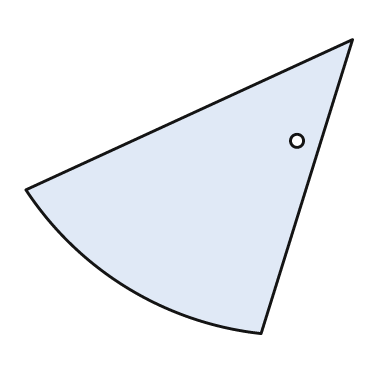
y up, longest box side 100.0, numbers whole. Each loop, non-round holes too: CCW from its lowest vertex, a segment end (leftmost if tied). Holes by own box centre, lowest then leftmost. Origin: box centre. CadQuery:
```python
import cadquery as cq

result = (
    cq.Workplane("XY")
    .moveTo(22.0, -45.0)
    .lineTo(50.0, 45.0)
    .lineTo(-50.0, -1.0)
    .threePointArc((-19.0, -31.0), (22.0, -45.0))
    .close()
    .moveTo(33.0, 14.0)
    .circle(2.0)
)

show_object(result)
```